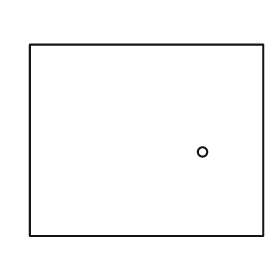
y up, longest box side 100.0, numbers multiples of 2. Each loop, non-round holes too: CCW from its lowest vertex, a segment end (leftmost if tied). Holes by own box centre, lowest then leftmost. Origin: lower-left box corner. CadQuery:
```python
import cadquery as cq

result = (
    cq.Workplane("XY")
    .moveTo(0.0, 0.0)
    .lineTo(100.0, 0.0)
    .lineTo(100.0, 82.0)
    .lineTo(0.0, 82.0)
    .close()
    .moveTo(74.0, 36.0)
    .circle(2.0)
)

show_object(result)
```